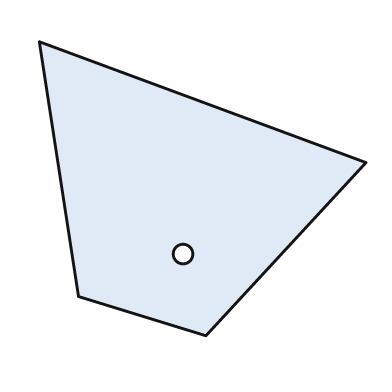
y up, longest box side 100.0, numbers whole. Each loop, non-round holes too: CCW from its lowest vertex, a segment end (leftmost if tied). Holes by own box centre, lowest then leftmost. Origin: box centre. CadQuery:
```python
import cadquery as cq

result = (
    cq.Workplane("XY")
    .moveTo(1.0, -45.0)
    .lineTo(50.0, 8.0)
    .lineTo(-50.0, 45.0)
    .lineTo(-38.0, -33.0)
    .close()
    .moveTo(-6.0, -20.0)
    .circle(3.0)
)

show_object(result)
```